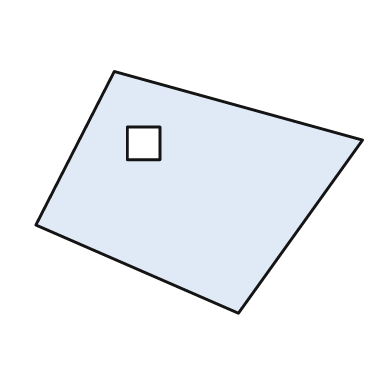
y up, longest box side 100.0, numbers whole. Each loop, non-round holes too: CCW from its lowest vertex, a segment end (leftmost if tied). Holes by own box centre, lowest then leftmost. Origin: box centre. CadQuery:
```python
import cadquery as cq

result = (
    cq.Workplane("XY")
    .moveTo(12.0, -37.0)
    .lineTo(50.0, 16.0)
    .lineTo(-26.0, 37.0)
    .lineTo(-50.0, -10.0)
    .close()
    .moveTo(-22.0, 10.0)
    .lineTo(-12.0, 10.0)
    .lineTo(-12.0, 20.0)
    .lineTo(-22.0, 20.0)
    .close()
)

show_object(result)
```